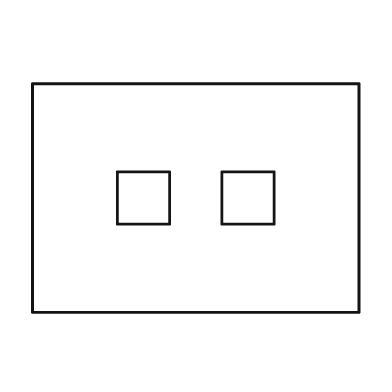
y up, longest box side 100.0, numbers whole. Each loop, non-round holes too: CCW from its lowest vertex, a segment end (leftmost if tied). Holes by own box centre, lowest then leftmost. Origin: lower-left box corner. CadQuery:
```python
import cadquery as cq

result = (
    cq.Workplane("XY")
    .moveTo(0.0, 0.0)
    .lineTo(100.0, 0.0)
    .lineTo(100.0, 70.0)
    .lineTo(0.0, 70.0)
    .close()
    .moveTo(26.0, 27.0)
    .lineTo(42.0, 27.0)
    .lineTo(42.0, 43.0)
    .lineTo(26.0, 43.0)
    .close()
    .moveTo(58.0, 27.0)
    .lineTo(74.0, 27.0)
    .lineTo(74.0, 43.0)
    .lineTo(58.0, 43.0)
    .close()
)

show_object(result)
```